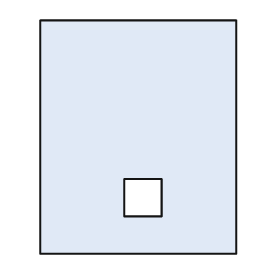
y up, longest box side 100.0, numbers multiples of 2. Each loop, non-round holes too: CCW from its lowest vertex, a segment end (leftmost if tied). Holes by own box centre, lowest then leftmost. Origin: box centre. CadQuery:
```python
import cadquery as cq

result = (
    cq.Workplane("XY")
    .moveTo(-42.0, -50.0)
    .lineTo(42.0, -50.0)
    .lineTo(42.0, 50.0)
    .lineTo(-42.0, 50.0)
    .close()
    .moveTo(-6.0, -34.0)
    .lineTo(10.0, -34.0)
    .lineTo(10.0, -18.0)
    .lineTo(-6.0, -18.0)
    .close()
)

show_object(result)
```